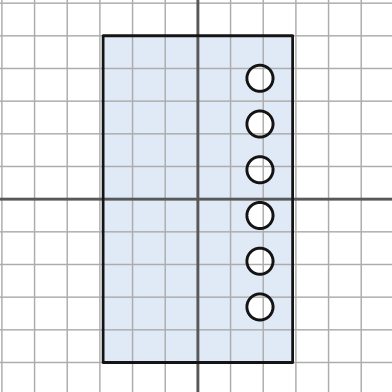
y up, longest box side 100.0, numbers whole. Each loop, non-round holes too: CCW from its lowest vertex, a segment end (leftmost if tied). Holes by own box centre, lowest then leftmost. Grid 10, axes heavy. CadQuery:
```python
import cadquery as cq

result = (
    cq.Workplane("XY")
    .moveTo(-29.0, -50.0)
    .lineTo(29.0, -50.0)
    .lineTo(29.0, 50.0)
    .lineTo(-29.0, 50.0)
    .close()
    .moveTo(19.0, -33.0)
    .circle(4.0)
    .moveTo(19.0, -19.0)
    .circle(4.0)
    .moveTo(19.0, -5.0)
    .circle(4.0)
    .moveTo(19.0, 9.0)
    .circle(4.0)
    .moveTo(19.0, 23.0)
    .circle(4.0)
    .moveTo(19.0, 37.0)
    .circle(4.0)
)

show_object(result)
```